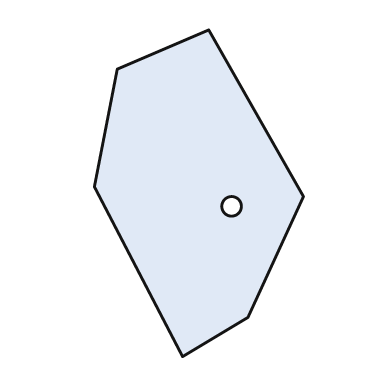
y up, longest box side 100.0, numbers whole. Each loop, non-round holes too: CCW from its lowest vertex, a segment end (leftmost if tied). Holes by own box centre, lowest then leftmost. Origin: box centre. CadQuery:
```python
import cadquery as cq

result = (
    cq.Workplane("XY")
    .moveTo(-5.0, -50.0)
    .lineTo(15.0, -38.0)
    .lineTo(32.0, -1.0)
    .lineTo(3.0, 50.0)
    .lineTo(-25.0, 38.0)
    .lineTo(-32.0, 2.0)
    .close()
    .moveTo(10.0, -4.0)
    .circle(3.0)
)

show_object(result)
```